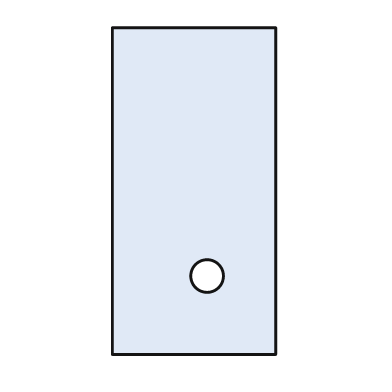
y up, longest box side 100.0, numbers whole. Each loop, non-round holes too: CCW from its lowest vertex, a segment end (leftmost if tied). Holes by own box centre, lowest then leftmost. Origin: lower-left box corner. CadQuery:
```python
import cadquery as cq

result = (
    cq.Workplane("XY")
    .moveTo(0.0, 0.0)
    .lineTo(50.0, 0.0)
    .lineTo(50.0, 100.0)
    .lineTo(0.0, 100.0)
    .close()
    .moveTo(29.0, 24.0)
    .circle(5.0)
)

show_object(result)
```